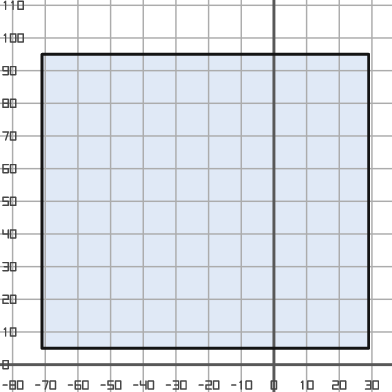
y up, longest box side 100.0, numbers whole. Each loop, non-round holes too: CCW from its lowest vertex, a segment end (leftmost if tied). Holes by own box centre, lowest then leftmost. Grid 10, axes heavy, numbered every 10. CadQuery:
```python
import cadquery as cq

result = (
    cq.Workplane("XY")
    .moveTo(-71.0, 5.0)
    .lineTo(29.0, 5.0)
    .lineTo(29.0, 95.0)
    .lineTo(-71.0, 95.0)
    .close()
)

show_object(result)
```